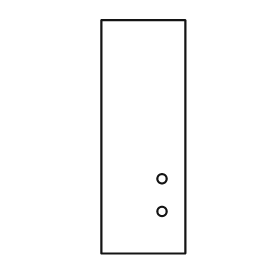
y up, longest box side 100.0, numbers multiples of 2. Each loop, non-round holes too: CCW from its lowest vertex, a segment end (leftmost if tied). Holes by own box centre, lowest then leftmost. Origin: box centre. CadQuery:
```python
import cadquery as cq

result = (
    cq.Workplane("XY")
    .moveTo(-18.0, -50.0)
    .lineTo(18.0, -50.0)
    .lineTo(18.0, 50.0)
    .lineTo(-18.0, 50.0)
    .close()
    .moveTo(8.0, -32.0)
    .circle(2.0)
    .moveTo(8.0, -18.0)
    .circle(2.0)
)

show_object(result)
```